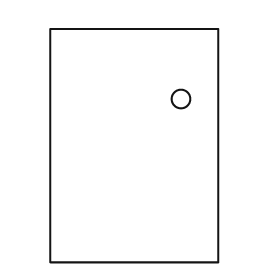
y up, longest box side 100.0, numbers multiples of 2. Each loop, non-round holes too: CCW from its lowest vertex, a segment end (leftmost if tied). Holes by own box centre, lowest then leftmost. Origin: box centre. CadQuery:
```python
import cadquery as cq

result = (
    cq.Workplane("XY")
    .moveTo(-36.0, -50.0)
    .lineTo(36.0, -50.0)
    .lineTo(36.0, 50.0)
    .lineTo(-36.0, 50.0)
    .close()
    .moveTo(20.0, 20.0)
    .circle(4.0)
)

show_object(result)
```